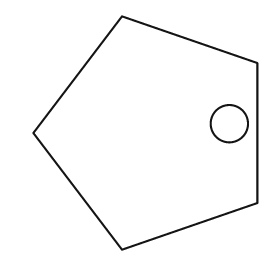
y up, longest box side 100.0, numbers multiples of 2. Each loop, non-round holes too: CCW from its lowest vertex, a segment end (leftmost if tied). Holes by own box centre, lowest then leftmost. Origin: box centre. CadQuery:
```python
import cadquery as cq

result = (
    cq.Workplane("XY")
    .moveTo(-10.0, -50.0)
    .lineTo(48.0, -30.0)
    .lineTo(48.0, 30.0)
    .lineTo(-10.0, 50.0)
    .lineTo(-48.0, 0.0)
    .close()
    .moveTo(36.0, 4.0)
    .circle(8.0)
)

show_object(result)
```